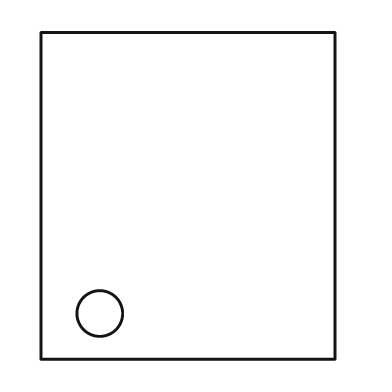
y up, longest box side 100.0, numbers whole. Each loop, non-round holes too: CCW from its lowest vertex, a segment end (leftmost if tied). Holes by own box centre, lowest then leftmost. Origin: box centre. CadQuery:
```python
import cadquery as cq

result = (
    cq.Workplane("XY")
    .moveTo(-45.0, -50.0)
    .lineTo(45.0, -50.0)
    .lineTo(45.0, 50.0)
    .lineTo(-45.0, 50.0)
    .close()
    .moveTo(-27.0, -36.0)
    .circle(7.0)
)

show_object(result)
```